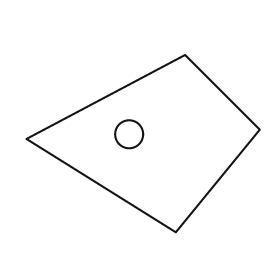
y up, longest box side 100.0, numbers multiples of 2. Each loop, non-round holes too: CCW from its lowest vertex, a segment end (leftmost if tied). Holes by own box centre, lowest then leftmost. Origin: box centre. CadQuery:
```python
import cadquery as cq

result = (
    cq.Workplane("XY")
    .moveTo(14.0, -38.0)
    .lineTo(50.0, 6.0)
    .lineTo(18.0, 38.0)
    .lineTo(-50.0, 2.0)
    .close()
    .moveTo(-6.0, 4.0)
    .circle(6.0)
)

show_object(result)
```